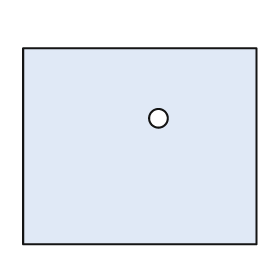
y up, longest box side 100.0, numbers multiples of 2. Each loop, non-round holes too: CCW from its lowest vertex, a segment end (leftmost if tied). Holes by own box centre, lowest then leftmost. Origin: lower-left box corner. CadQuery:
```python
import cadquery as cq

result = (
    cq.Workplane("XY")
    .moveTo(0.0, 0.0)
    .lineTo(100.0, 0.0)
    .lineTo(100.0, 84.0)
    .lineTo(0.0, 84.0)
    .close()
    .moveTo(58.0, 54.0)
    .circle(4.0)
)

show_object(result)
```